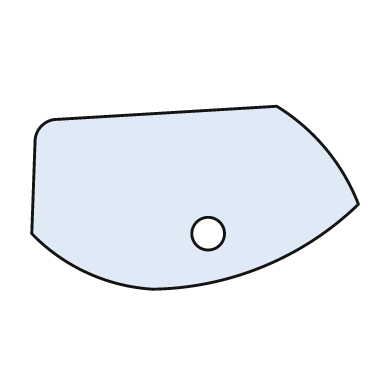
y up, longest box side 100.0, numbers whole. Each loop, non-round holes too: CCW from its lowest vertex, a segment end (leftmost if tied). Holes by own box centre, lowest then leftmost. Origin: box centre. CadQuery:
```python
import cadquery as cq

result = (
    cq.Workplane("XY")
    .moveTo(-13.0, -28.0)
    .threePointArc((21.0, -21.0), (50.0, -2.0))
    .threePointArc((40.0, 15.0), (25.0, 28.0))
    .lineTo(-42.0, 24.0)
    .threePointArc((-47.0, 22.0), (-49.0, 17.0))
    .lineTo(-50.0, -11.0)
    .threePointArc((-33.0, -23.0), (-13.0, -28.0))
    .close()
    .moveTo(4.0, -11.0)
    .circle(5.0)
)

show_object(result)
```